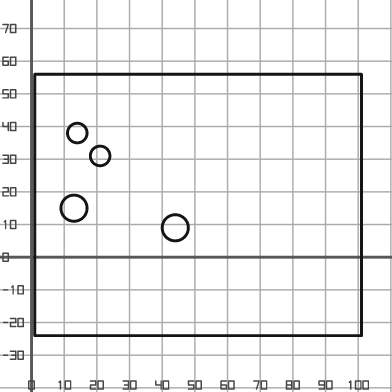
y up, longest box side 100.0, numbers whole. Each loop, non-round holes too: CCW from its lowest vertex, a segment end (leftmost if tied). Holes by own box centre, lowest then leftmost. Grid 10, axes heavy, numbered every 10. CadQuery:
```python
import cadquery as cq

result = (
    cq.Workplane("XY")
    .moveTo(1.0, -24.0)
    .lineTo(101.0, -24.0)
    .lineTo(101.0, 56.0)
    .lineTo(1.0, 56.0)
    .close()
    .moveTo(44.0, 9.0)
    .circle(4.0)
    .moveTo(13.0, 15.0)
    .circle(4.0)
    .moveTo(21.0, 31.0)
    .circle(3.0)
    .moveTo(14.0, 38.0)
    .circle(3.0)
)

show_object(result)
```